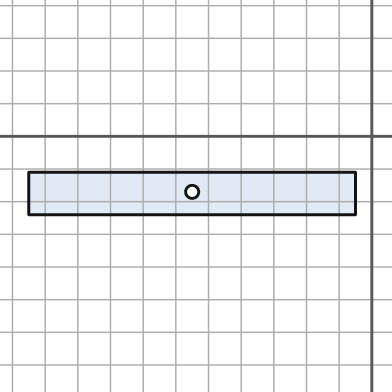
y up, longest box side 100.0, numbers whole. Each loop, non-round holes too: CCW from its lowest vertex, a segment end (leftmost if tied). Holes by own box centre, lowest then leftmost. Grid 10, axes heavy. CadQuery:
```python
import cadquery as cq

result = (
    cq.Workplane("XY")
    .moveTo(-105.0, -24.0)
    .lineTo(-5.0, -24.0)
    .lineTo(-5.0, -11.0)
    .lineTo(-105.0, -11.0)
    .close()
    .moveTo(-55.0, -17.0)
    .circle(2.0)
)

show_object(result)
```